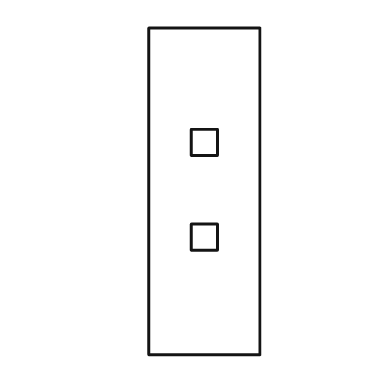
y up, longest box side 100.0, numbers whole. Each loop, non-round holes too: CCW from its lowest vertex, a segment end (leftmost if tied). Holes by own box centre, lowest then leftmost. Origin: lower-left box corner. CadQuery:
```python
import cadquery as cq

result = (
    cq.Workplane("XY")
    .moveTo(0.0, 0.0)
    .lineTo(34.0, 0.0)
    .lineTo(34.0, 100.0)
    .lineTo(0.0, 100.0)
    .close()
    .moveTo(13.0, 32.0)
    .lineTo(21.0, 32.0)
    .lineTo(21.0, 40.0)
    .lineTo(13.0, 40.0)
    .close()
    .moveTo(13.0, 61.0)
    .lineTo(21.0, 61.0)
    .lineTo(21.0, 69.0)
    .lineTo(13.0, 69.0)
    .close()
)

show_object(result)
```